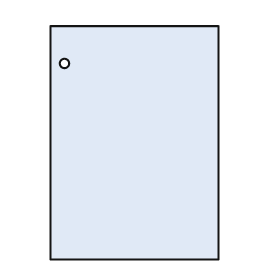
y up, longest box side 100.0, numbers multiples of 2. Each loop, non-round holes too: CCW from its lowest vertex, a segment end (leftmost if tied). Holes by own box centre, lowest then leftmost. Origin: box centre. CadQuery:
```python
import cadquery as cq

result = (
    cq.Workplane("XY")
    .moveTo(-36.0, -50.0)
    .lineTo(36.0, -50.0)
    .lineTo(36.0, 50.0)
    .lineTo(-36.0, 50.0)
    .close()
    .moveTo(-30.0, 34.0)
    .circle(2.0)
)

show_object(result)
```